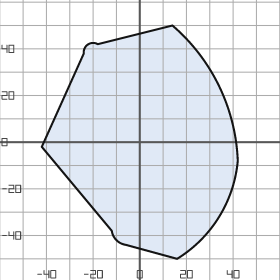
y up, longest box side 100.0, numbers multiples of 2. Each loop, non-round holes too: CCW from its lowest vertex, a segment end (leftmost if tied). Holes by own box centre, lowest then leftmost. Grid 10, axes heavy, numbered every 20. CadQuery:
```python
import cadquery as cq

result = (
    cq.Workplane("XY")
    .moveTo(16.0, -50.0)
    .threePointArc((34.0, -32.0), (42.0, -8.0))
    .threePointArc((34.0, 24.0), (14.0, 50.0))
    .lineTo(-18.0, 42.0)
    .threePointArc((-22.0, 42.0), (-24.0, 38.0))
    .lineTo(-42.0, -2.0)
    .lineTo(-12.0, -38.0)
    .threePointArc((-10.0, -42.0), (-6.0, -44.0))
    .close()
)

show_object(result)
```